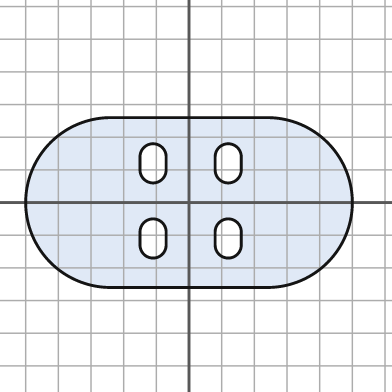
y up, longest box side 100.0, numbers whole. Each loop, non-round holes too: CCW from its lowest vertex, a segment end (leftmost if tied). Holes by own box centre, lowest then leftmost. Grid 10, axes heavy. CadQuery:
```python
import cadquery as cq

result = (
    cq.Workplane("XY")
    .moveTo(-24.0, -26.0)
    .lineTo(24.0, -26.0)
    .threePointArc((50.0, 0.0), (24.0, 26.0))
    .lineTo(-24.0, 26.0)
    .threePointArc((-50.0, 0.0), (-24.0, -26.0))
    .close()
    .moveTo(-15.0, -13.0)
    .threePointArc((-11.0, -17.0), (-7.0, -13.0))
    .lineTo(-7.0, -9.0)
    .threePointArc((-11.0, -5.0), (-15.0, -9.0))
    .close()
    .moveTo(8.0, -13.0)
    .threePointArc((12.0, -17.0), (16.0, -13.0))
    .lineTo(16.0, -9.0)
    .threePointArc((12.0, -5.0), (8.0, -9.0))
    .close()
    .moveTo(-15.0, 10.0)
    .threePointArc((-11.0, 6.0), (-7.0, 10.0))
    .lineTo(-7.0, 14.0)
    .threePointArc((-11.0, 18.0), (-15.0, 14.0))
    .close()
    .moveTo(8.0, 10.0)
    .threePointArc((12.0, 6.0), (16.0, 10.0))
    .lineTo(16.0, 14.0)
    .threePointArc((12.0, 18.0), (8.0, 14.0))
    .close()
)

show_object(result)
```